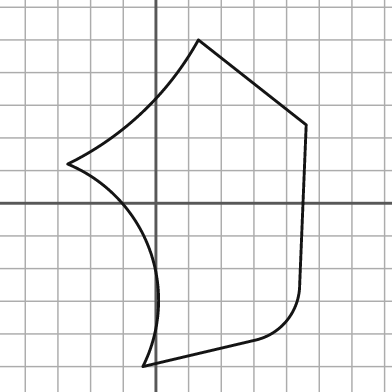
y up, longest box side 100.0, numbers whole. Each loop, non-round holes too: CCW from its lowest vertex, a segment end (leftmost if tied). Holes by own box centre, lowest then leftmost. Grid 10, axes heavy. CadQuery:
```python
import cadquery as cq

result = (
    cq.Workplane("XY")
    .moveTo(-4.0, -50.0)
    .lineTo(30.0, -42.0)
    .threePointArc((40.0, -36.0), (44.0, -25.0))
    .lineTo(46.0, 24.0)
    .lineTo(13.0, 50.0)
    .threePointArc((-4.0, 28.0), (-27.0, 12.0))
    .threePointArc((-2.0, -14.0), (-4.0, -50.0))
    .close()
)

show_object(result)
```